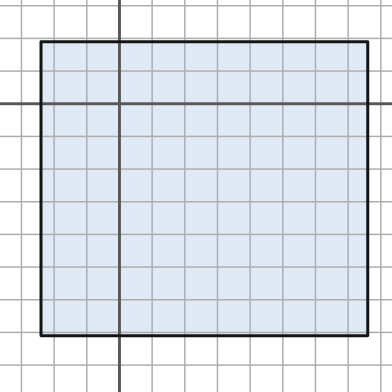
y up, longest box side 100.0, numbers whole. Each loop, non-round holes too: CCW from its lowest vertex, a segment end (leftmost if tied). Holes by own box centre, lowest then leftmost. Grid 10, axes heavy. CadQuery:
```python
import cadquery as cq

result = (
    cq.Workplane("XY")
    .moveTo(-24.0, -71.0)
    .lineTo(76.0, -71.0)
    .lineTo(76.0, 19.0)
    .lineTo(-24.0, 19.0)
    .close()
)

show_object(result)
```